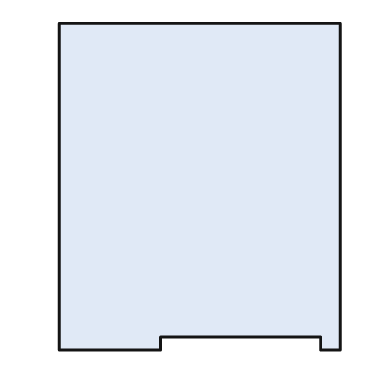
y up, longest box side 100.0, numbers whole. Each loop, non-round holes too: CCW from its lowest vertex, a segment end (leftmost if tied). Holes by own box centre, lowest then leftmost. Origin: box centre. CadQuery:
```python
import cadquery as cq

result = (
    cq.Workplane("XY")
    .moveTo(-43.0, -50.0)
    .lineTo(-12.0, -50.0)
    .lineTo(-12.0, -46.0)
    .lineTo(37.0, -46.0)
    .lineTo(37.0, -50.0)
    .lineTo(43.0, -50.0)
    .lineTo(43.0, 50.0)
    .lineTo(-43.0, 50.0)
    .close()
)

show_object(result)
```